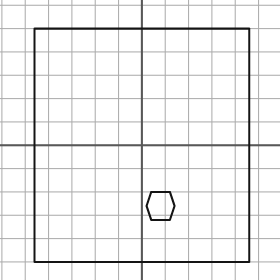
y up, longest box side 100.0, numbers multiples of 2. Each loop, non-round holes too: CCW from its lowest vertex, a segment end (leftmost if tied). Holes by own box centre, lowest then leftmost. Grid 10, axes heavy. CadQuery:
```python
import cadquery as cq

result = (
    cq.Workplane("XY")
    .moveTo(-46.0, -50.0)
    .lineTo(46.0, -50.0)
    .lineTo(46.0, 50.0)
    .lineTo(-46.0, 50.0)
    .close()
    .moveTo(4.0, -32.0)
    .lineTo(12.0, -32.0)
    .lineTo(14.0, -26.0)
    .lineTo(12.0, -20.0)
    .lineTo(4.0, -20.0)
    .lineTo(2.0, -26.0)
    .close()
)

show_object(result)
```